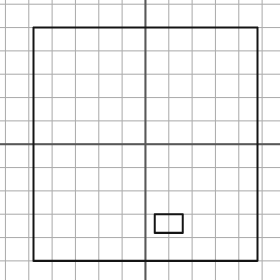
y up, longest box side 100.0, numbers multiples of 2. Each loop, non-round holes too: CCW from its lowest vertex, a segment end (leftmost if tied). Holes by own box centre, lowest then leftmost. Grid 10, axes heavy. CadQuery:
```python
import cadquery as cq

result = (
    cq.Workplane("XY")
    .moveTo(-48.0, -50.0)
    .lineTo(48.0, -50.0)
    .lineTo(48.0, 50.0)
    .lineTo(-48.0, 50.0)
    .close()
    .moveTo(4.0, -38.0)
    .lineTo(16.0, -38.0)
    .lineTo(16.0, -30.0)
    .lineTo(4.0, -30.0)
    .close()
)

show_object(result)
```